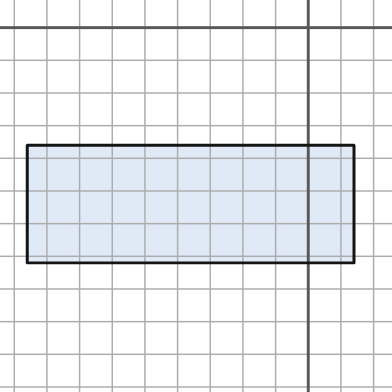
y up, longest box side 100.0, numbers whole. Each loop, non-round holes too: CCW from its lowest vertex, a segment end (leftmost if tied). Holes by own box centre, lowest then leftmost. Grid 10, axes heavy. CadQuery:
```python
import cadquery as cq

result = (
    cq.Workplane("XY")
    .moveTo(-86.0, -72.0)
    .lineTo(14.0, -72.0)
    .lineTo(14.0, -36.0)
    .lineTo(-86.0, -36.0)
    .close()
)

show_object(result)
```